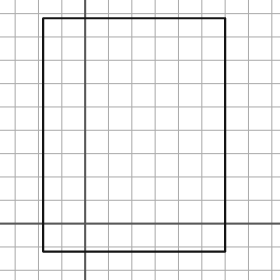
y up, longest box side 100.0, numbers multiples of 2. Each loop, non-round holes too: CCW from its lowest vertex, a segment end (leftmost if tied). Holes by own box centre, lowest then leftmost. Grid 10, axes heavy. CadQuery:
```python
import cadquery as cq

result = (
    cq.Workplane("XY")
    .moveTo(-18.0, -12.0)
    .lineTo(60.0, -12.0)
    .lineTo(60.0, 88.0)
    .lineTo(-18.0, 88.0)
    .close()
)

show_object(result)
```